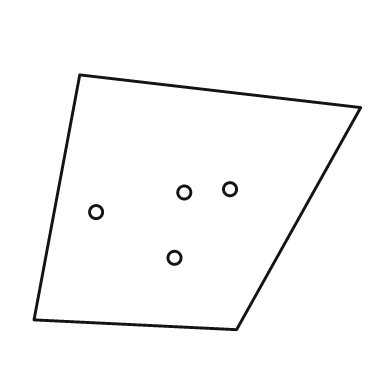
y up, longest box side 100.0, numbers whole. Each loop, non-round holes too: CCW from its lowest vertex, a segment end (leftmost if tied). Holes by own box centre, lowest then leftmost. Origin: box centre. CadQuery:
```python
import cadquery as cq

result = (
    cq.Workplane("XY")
    .moveTo(12.0, -39.0)
    .lineTo(50.0, 29.0)
    .lineTo(-36.0, 39.0)
    .lineTo(-50.0, -36.0)
    .close()
    .moveTo(-7.0, -17.0)
    .circle(2.0)
    .moveTo(-31.0, -3.0)
    .circle(2.0)
    .moveTo(-4.0, 3.0)
    .circle(2.0)
    .moveTo(10.0, 4.0)
    .circle(2.0)
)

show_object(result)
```